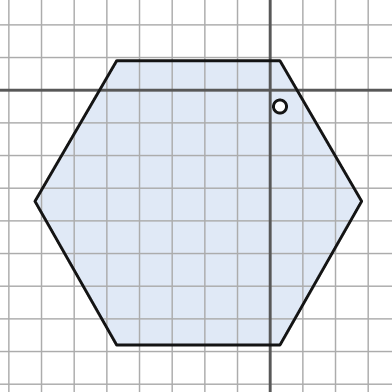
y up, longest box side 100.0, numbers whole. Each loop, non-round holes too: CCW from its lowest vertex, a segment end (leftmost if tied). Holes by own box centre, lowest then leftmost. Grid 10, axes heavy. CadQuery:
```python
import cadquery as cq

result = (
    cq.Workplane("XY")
    .moveTo(-47.0, -78.0)
    .lineTo(3.0, -78.0)
    .lineTo(28.0, -34.0)
    .lineTo(3.0, 9.0)
    .lineTo(-47.0, 9.0)
    .lineTo(-72.0, -34.0)
    .close()
    .moveTo(3.0, -5.0)
    .circle(2.0)
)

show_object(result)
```